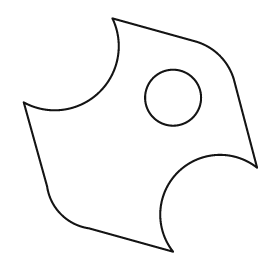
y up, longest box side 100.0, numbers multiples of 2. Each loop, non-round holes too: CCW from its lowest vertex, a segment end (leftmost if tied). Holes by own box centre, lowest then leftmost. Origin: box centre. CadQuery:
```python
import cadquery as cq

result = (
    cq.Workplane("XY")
    .moveTo(14.0, -50.0)
    .threePointArc((16.0, -16.0), (50.0, -14.0))
    .lineTo(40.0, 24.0)
    .threePointArc((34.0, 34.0), (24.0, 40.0))
    .lineTo(-12.0, 50.0)
    .threePointArc((-18.0, 18.0), (-50.0, 14.0))
    .lineTo(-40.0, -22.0)
    .threePointArc((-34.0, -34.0), (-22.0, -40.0))
    .close()
    .moveTo(14.0, 16.0)
    .circle(12.0)
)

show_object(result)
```